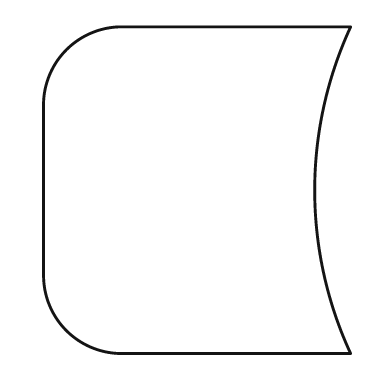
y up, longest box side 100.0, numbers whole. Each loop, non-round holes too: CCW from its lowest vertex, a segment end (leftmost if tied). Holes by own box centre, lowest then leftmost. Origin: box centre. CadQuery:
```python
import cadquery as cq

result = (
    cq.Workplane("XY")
    .moveTo(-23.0, -50.0)
    .lineTo(47.0, -50.0)
    .threePointArc((36.0, 0.0), (47.0, 50.0))
    .lineTo(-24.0, 50.0)
    .threePointArc((-40.0, 43.0), (-47.0, 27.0))
    .lineTo(-47.0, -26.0)
    .threePointArc((-40.0, -43.0), (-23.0, -50.0))
    .close()
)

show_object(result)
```